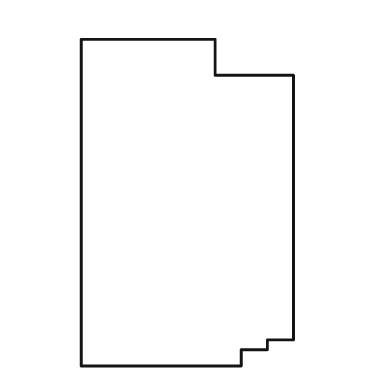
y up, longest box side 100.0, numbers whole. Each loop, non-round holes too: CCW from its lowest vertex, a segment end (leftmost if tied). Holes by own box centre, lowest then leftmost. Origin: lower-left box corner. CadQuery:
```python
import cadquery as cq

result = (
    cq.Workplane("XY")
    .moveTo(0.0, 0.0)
    .lineTo(49.0, 0.0)
    .lineTo(49.0, 5.0)
    .lineTo(57.0, 5.0)
    .lineTo(57.0, 8.0)
    .lineTo(65.0, 8.0)
    .lineTo(65.0, 89.0)
    .lineTo(41.0, 89.0)
    .lineTo(41.0, 100.0)
    .lineTo(0.0, 100.0)
    .close()
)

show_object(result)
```